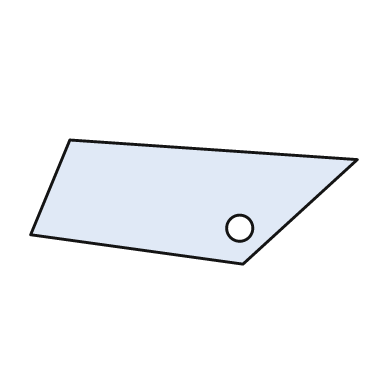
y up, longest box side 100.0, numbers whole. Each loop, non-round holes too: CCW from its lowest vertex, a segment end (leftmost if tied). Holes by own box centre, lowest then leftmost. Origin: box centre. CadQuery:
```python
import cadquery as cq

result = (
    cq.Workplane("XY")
    .moveTo(15.0, -19.0)
    .lineTo(50.0, 13.0)
    .lineTo(-38.0, 19.0)
    .lineTo(-50.0, -10.0)
    .close()
    .moveTo(14.0, -8.0)
    .circle(4.0)
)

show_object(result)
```